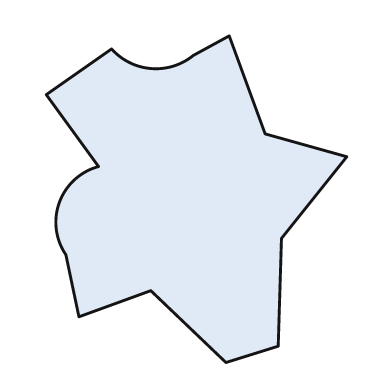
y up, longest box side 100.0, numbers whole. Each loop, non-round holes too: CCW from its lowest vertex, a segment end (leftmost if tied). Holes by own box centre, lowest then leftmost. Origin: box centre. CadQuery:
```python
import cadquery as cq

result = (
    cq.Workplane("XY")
    .moveTo(9.0, -50.0)
    .lineTo(25.0, -45.0)
    .lineTo(26.0, -12.0)
    .lineTo(46.0, 13.0)
    .lineTo(21.0, 20.0)
    .lineTo(10.0, 50.0)
    .lineTo(-1.0, 44.0)
    .threePointArc((-14.0, 40.0), (-26.0, 46.0))
    .lineTo(-46.0, 32.0)
    .lineTo(-30.0, 10.0)
    .threePointArc((-42.0, -1.0), (-40.0, -17.0))
    .lineTo(-36.0, -36.0)
    .lineTo(-14.0, -28.0)
    .close()
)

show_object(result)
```